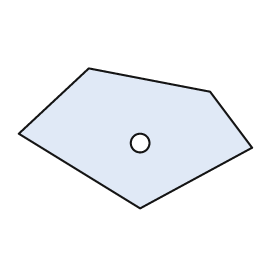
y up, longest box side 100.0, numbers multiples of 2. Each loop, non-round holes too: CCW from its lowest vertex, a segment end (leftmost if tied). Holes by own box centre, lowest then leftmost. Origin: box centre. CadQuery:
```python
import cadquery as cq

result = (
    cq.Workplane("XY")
    .moveTo(2.0, -30.0)
    .lineTo(50.0, -4.0)
    .lineTo(32.0, 20.0)
    .lineTo(-20.0, 30.0)
    .lineTo(-50.0, 2.0)
    .close()
    .moveTo(2.0, -2.0)
    .circle(4.0)
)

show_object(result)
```